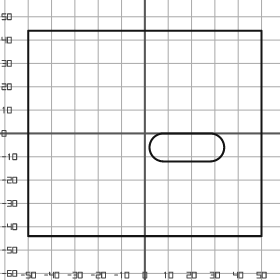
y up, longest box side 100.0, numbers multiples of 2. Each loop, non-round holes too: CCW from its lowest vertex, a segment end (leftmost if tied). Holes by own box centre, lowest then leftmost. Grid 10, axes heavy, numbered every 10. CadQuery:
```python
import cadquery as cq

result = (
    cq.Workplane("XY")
    .moveTo(-50.0, -44.0)
    .lineTo(50.0, -44.0)
    .lineTo(50.0, 44.0)
    .lineTo(-50.0, 44.0)
    .close()
    .moveTo(8.0, -12.0)
    .lineTo(28.0, -12.0)
    .threePointArc((34.0, -6.0), (28.0, 0.0))
    .lineTo(8.0, 0.0)
    .threePointArc((2.0, -6.0), (8.0, -12.0))
    .close()
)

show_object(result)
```